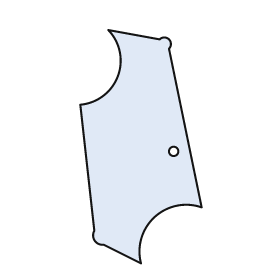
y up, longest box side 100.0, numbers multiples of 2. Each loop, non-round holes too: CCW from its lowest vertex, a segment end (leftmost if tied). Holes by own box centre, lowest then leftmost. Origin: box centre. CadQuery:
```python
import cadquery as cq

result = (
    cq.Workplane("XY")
    .moveTo(0.0, -50.0)
    .threePointArc((6.0, -30.0), (26.0, -26.0))
    .lineTo(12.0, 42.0)
    .threePointArc((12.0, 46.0), (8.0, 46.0))
    .lineTo(-14.0, 50.0)
    .threePointArc((-10.0, 30.0), (-26.0, 18.0))
    .lineTo(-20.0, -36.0)
    .threePointArc((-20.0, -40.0), (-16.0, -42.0))
    .close()
    .moveTo(14.0, -2.0)
    .circle(2.0)
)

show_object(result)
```